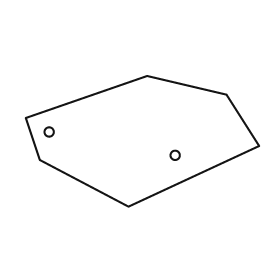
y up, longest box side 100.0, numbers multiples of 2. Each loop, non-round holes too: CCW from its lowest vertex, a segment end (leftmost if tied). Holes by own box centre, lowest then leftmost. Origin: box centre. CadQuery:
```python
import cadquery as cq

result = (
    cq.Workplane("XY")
    .moveTo(-6.0, -28.0)
    .lineTo(50.0, -2.0)
    .lineTo(36.0, 20.0)
    .lineTo(2.0, 28.0)
    .lineTo(-50.0, 10.0)
    .lineTo(-44.0, -8.0)
    .close()
    .moveTo(14.0, -6.0)
    .circle(2.0)
    .moveTo(-40.0, 4.0)
    .circle(2.0)
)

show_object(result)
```